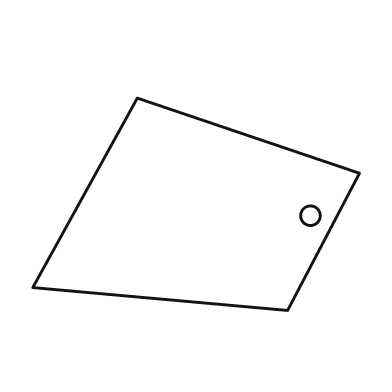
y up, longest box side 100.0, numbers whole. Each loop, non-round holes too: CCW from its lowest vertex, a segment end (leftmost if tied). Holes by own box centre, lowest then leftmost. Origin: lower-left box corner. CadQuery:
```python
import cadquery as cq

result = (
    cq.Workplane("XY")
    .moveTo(78.0, 0.0)
    .lineTo(100.0, 42.0)
    .lineTo(32.0, 65.0)
    .lineTo(0.0, 7.0)
    .close()
    .moveTo(85.0, 29.0)
    .circle(3.0)
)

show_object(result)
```